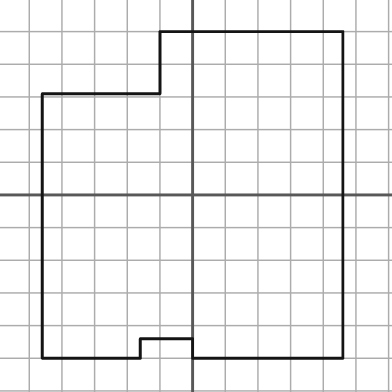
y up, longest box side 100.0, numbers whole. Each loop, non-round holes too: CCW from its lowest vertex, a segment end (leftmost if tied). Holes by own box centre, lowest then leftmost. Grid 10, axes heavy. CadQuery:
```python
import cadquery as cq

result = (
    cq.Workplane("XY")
    .moveTo(-46.0, -50.0)
    .lineTo(-16.0, -50.0)
    .lineTo(-16.0, -44.0)
    .lineTo(0.0, -44.0)
    .lineTo(0.0, -50.0)
    .lineTo(46.0, -50.0)
    .lineTo(46.0, 50.0)
    .lineTo(-10.0, 50.0)
    .lineTo(-10.0, 31.0)
    .lineTo(-46.0, 31.0)
    .close()
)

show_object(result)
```